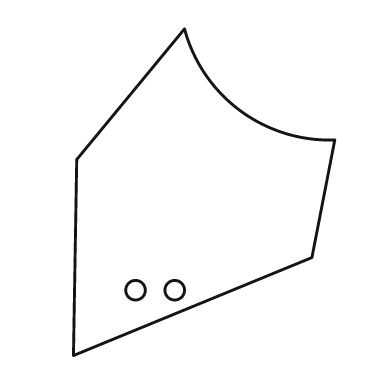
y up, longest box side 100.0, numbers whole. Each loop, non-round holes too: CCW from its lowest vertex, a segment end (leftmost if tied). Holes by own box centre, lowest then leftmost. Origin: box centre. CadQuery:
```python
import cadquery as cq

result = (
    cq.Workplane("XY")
    .moveTo(-40.0, -50.0)
    .lineTo(33.0, -20.0)
    .lineTo(40.0, 16.0)
    .threePointArc((11.0, 25.0), (-6.0, 50.0))
    .lineTo(-39.0, 10.0)
    .close()
    .moveTo(-21.0, -30.0)
    .circle(3.0)
    .moveTo(-9.0, -30.0)
    .circle(3.0)
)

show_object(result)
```